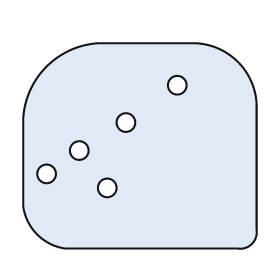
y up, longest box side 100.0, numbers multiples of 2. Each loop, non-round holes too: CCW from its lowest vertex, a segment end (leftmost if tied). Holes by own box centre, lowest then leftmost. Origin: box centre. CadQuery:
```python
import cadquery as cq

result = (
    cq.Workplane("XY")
    .moveTo(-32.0, -44.0)
    .lineTo(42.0, -44.0)
    .threePointArc((48.0, -42.0), (50.0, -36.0))
    .lineTo(50.0, 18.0)
    .threePointArc((42.0, 36.0), (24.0, 44.0))
    .lineTo(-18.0, 44.0)
    .threePointArc((-40.0, 34.0), (-50.0, 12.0))
    .lineTo(-50.0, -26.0)
    .threePointArc((-44.0, -38.0), (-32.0, -44.0))
    .close()
    .moveTo(-14.0, -18.0)
    .circle(4.0)
    .moveTo(-40.0, -12.0)
    .circle(4.0)
    .moveTo(-26.0, -2.0)
    .circle(4.0)
    .moveTo(-6.0, 10.0)
    .circle(4.0)
    .moveTo(16.0, 26.0)
    .circle(4.0)
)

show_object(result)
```